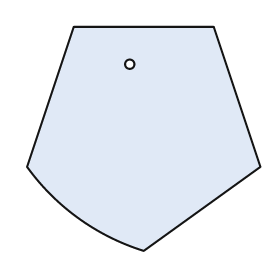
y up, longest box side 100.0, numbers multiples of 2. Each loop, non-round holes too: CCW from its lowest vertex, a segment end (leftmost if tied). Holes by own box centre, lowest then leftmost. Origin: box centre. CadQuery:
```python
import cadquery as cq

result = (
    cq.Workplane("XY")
    .moveTo(0.0, -48.0)
    .lineTo(50.0, -12.0)
    .lineTo(30.0, 48.0)
    .lineTo(-30.0, 48.0)
    .lineTo(-50.0, -12.0)
    .threePointArc((-28.0, -34.0), (0.0, -48.0))
    .close()
    .moveTo(-6.0, 32.0)
    .circle(2.0)
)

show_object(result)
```